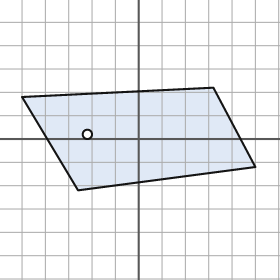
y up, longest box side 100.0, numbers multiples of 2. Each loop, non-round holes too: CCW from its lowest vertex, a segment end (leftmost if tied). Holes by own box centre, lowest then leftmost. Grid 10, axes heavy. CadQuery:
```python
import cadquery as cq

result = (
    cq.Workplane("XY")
    .moveTo(-26.0, -22.0)
    .lineTo(50.0, -12.0)
    .lineTo(32.0, 22.0)
    .lineTo(-50.0, 18.0)
    .close()
    .moveTo(-22.0, 2.0)
    .circle(2.0)
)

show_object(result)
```